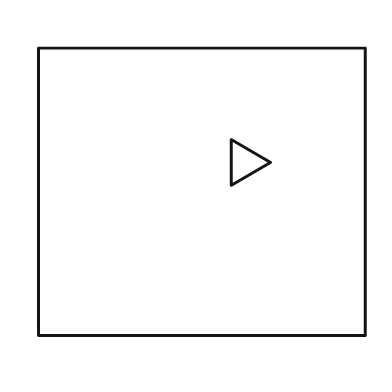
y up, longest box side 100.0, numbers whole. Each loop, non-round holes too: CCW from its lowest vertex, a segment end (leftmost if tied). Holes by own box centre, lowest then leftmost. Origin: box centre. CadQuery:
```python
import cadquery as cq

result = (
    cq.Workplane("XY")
    .moveTo(-50.0, -44.0)
    .lineTo(50.0, -44.0)
    .lineTo(50.0, 44.0)
    .lineTo(-50.0, 44.0)
    .close()
    .moveTo(9.0, 2.0)
    .lineTo(21.0, 9.0)
    .lineTo(9.0, 16.0)
    .close()
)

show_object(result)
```